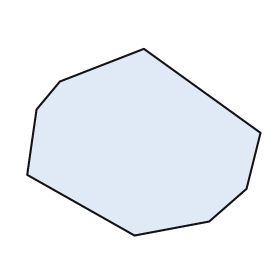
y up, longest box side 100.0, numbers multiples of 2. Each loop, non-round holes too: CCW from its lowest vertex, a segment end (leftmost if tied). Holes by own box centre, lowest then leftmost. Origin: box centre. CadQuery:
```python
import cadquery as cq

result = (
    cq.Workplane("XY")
    .moveTo(-4.0, -40.0)
    .lineTo(28.0, -34.0)
    .lineTo(44.0, -20.0)
    .lineTo(50.0, 4.0)
    .lineTo(0.0, 40.0)
    .lineTo(-36.0, 26.0)
    .lineTo(-46.0, 14.0)
    .lineTo(-50.0, -14.0)
    .close()
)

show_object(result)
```